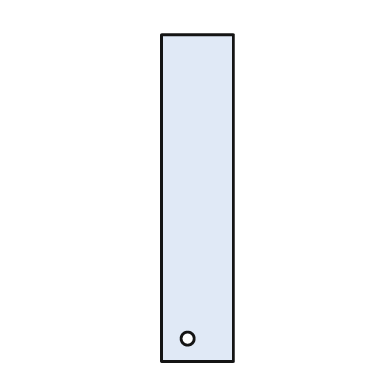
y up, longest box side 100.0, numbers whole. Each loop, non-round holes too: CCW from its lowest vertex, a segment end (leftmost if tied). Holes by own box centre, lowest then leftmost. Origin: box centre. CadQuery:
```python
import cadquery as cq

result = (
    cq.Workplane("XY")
    .moveTo(-11.0, -50.0)
    .lineTo(11.0, -50.0)
    .lineTo(11.0, 50.0)
    .lineTo(-11.0, 50.0)
    .close()
    .moveTo(-3.0, -43.0)
    .circle(2.0)
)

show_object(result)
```